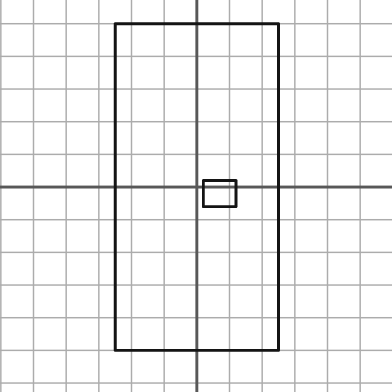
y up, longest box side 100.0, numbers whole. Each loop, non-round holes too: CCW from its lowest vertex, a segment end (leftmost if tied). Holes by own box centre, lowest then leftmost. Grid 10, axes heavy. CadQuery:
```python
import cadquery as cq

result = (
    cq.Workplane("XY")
    .moveTo(-25.0, -50.0)
    .lineTo(25.0, -50.0)
    .lineTo(25.0, 50.0)
    .lineTo(-25.0, 50.0)
    .close()
    .moveTo(2.0, -6.0)
    .lineTo(12.0, -6.0)
    .lineTo(12.0, 2.0)
    .lineTo(2.0, 2.0)
    .close()
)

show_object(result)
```